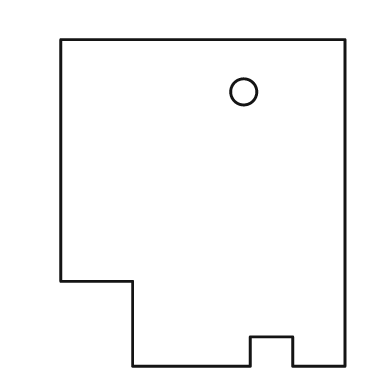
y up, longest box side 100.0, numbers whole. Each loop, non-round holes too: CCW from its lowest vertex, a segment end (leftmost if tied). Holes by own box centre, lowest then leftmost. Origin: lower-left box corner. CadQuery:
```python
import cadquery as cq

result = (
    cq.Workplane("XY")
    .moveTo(22.0, 0.0)
    .lineTo(58.0, 0.0)
    .lineTo(58.0, 9.0)
    .lineTo(71.0, 9.0)
    .lineTo(71.0, 0.0)
    .lineTo(87.0, 0.0)
    .lineTo(87.0, 100.0)
    .lineTo(0.0, 100.0)
    .lineTo(0.0, 26.0)
    .lineTo(22.0, 26.0)
    .close()
    .moveTo(56.0, 84.0)
    .circle(4.0)
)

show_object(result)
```